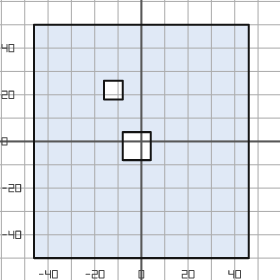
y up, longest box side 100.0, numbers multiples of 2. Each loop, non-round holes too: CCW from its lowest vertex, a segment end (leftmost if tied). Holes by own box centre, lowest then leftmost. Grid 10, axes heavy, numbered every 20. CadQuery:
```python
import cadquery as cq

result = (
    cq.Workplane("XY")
    .moveTo(-46.0, -50.0)
    .lineTo(46.0, -50.0)
    .lineTo(46.0, 50.0)
    .lineTo(-46.0, 50.0)
    .close()
    .moveTo(-8.0, -8.0)
    .lineTo(4.0, -8.0)
    .lineTo(4.0, 4.0)
    .lineTo(-8.0, 4.0)
    .close()
    .moveTo(-16.0, 18.0)
    .lineTo(-8.0, 18.0)
    .lineTo(-8.0, 26.0)
    .lineTo(-16.0, 26.0)
    .close()
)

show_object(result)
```